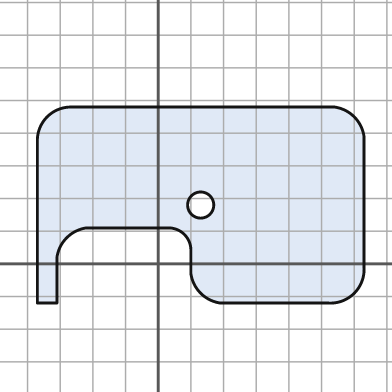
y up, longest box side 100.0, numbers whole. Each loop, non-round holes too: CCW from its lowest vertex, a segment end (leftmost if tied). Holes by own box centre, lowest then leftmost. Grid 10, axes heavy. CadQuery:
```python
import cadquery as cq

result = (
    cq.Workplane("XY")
    .moveTo(-37.0, -12.0)
    .lineTo(-31.0, -12.0)
    .lineTo(-31.0, 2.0)
    .threePointArc((-28.0, 8.0), (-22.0, 11.0))
    .lineTo(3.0, 11.0)
    .threePointArc((8.0, 9.0), (10.0, 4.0))
    .lineTo(10.0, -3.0)
    .threePointArc((13.0, -9.0), (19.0, -12.0))
    .lineTo(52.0, -12.0)
    .threePointArc((60.0, -9.0), (63.0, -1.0))
    .lineTo(63.0, 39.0)
    .threePointArc((60.0, 45.0), (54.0, 48.0))
    .lineTo(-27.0, 48.0)
    .threePointArc((-34.0, 45.0), (-37.0, 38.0))
    .close()
    .moveTo(13.0, 18.0)
    .circle(4.0)
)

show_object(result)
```